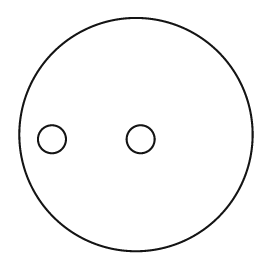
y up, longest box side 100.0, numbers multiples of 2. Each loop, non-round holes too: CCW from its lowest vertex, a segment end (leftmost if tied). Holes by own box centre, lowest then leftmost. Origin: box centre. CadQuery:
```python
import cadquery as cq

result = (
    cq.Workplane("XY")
    .moveTo(0.0, 0.0)
    .circle(50.0)
    .moveTo(-36.0, -2.0)
    .circle(6.0)
    .moveTo(2.0, -2.0)
    .circle(6.0)
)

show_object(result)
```